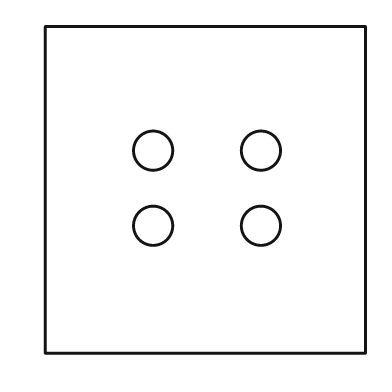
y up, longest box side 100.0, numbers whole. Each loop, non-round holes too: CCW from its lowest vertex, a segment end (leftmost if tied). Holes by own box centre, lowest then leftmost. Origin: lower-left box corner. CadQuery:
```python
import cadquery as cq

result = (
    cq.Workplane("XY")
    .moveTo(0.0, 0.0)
    .lineTo(98.0, 0.0)
    .lineTo(98.0, 100.0)
    .lineTo(0.0, 100.0)
    .close()
    .moveTo(33.0, 39.0)
    .circle(6.0)
    .moveTo(66.0, 39.0)
    .circle(6.0)
    .moveTo(33.0, 62.0)
    .circle(6.0)
    .moveTo(66.0, 62.0)
    .circle(6.0)
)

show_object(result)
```